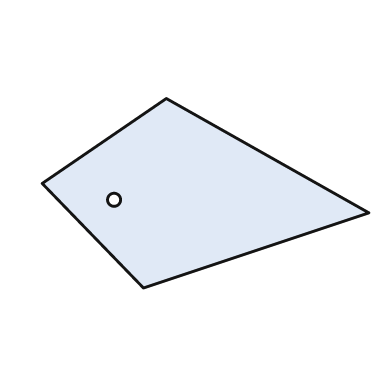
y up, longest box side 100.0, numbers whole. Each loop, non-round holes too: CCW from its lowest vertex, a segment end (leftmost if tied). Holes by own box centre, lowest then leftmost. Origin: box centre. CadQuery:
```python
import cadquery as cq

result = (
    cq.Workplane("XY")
    .moveTo(-19.0, -29.0)
    .lineTo(50.0, -6.0)
    .lineTo(-12.0, 29.0)
    .lineTo(-50.0, 3.0)
    .close()
    .moveTo(-28.0, -2.0)
    .circle(2.0)
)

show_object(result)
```